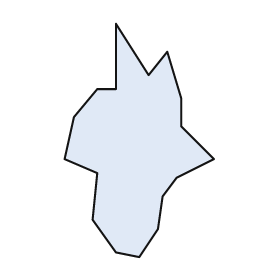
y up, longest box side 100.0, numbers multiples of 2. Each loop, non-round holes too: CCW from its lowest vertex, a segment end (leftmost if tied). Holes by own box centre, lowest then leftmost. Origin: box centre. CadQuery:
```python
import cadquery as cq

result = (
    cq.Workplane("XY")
    .moveTo(0.0, -50.0)
    .lineTo(8.0, -38.0)
    .lineTo(10.0, -24.0)
    .lineTo(16.0, -16.0)
    .lineTo(32.0, -8.0)
    .lineTo(18.0, 6.0)
    .lineTo(18.0, 18.0)
    .lineTo(12.0, 38.0)
    .lineTo(4.0, 28.0)
    .lineTo(-10.0, 50.0)
    .lineTo(-10.0, 22.0)
    .lineTo(-18.0, 22.0)
    .lineTo(-28.0, 10.0)
    .lineTo(-32.0, -8.0)
    .lineTo(-18.0, -14.0)
    .lineTo(-20.0, -34.0)
    .lineTo(-10.0, -48.0)
    .close()
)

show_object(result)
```